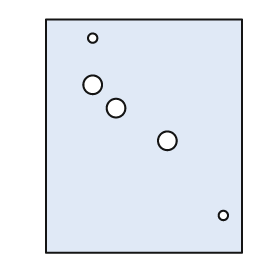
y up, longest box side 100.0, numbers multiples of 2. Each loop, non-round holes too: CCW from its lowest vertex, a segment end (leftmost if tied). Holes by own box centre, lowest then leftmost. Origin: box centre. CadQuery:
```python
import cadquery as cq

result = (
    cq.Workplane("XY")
    .moveTo(-42.0, -50.0)
    .lineTo(42.0, -50.0)
    .lineTo(42.0, 50.0)
    .lineTo(-42.0, 50.0)
    .close()
    .moveTo(34.0, -34.0)
    .circle(2.0)
    .moveTo(10.0, -2.0)
    .circle(4.0)
    .moveTo(-12.0, 12.0)
    .circle(4.0)
    .moveTo(-22.0, 22.0)
    .circle(4.0)
    .moveTo(-22.0, 42.0)
    .circle(2.0)
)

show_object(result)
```